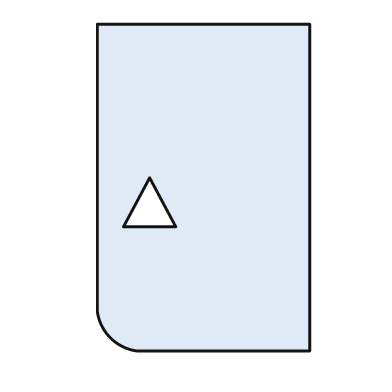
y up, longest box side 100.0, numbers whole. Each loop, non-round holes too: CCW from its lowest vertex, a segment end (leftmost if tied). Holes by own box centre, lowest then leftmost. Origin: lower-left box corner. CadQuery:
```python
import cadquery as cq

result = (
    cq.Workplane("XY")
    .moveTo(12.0, 0.0)
    .lineTo(65.0, 0.0)
    .lineTo(65.0, 100.0)
    .lineTo(0.0, 100.0)
    .lineTo(0.0, 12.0)
    .threePointArc((4.0, 4.0), (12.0, 0.0))
    .close()
    .moveTo(8.0, 38.0)
    .lineTo(24.0, 38.0)
    .lineTo(16.0, 53.0)
    .close()
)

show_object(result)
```